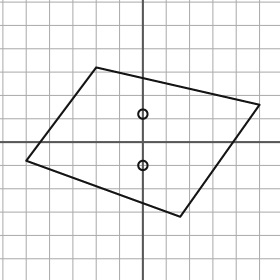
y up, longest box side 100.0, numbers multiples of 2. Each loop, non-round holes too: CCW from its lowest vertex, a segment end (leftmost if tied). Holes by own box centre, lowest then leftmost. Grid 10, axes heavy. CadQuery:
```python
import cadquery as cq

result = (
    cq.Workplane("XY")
    .moveTo(16.0, -32.0)
    .lineTo(50.0, 16.0)
    .lineTo(-20.0, 32.0)
    .lineTo(-50.0, -8.0)
    .close()
    .moveTo(0.0, -10.0)
    .circle(2.0)
    .moveTo(0.0, 12.0)
    .circle(2.0)
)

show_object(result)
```